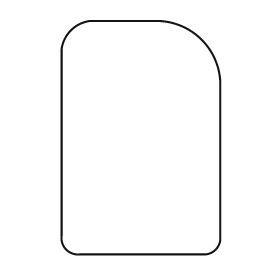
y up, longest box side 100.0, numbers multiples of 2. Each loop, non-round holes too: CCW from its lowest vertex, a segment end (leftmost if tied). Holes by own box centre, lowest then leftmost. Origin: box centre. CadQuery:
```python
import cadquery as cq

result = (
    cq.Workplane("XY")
    .moveTo(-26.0, -50.0)
    .lineTo(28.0, -50.0)
    .threePointArc((32.0, -48.0), (34.0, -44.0))
    .lineTo(34.0, 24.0)
    .threePointArc((26.0, 42.0), (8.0, 50.0))
    .lineTo(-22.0, 50.0)
    .threePointArc((-30.0, 46.0), (-34.0, 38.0))
    .lineTo(-34.0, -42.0)
    .threePointArc((-32.0, -48.0), (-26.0, -50.0))
    .close()
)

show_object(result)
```